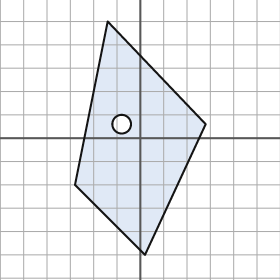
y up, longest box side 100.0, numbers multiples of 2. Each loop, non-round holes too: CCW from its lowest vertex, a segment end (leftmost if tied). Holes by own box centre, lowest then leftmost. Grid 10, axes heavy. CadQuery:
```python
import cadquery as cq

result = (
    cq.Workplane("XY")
    .moveTo(2.0, -50.0)
    .lineTo(28.0, 6.0)
    .lineTo(-14.0, 50.0)
    .lineTo(-28.0, -20.0)
    .close()
    .moveTo(-8.0, 6.0)
    .circle(4.0)
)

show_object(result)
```